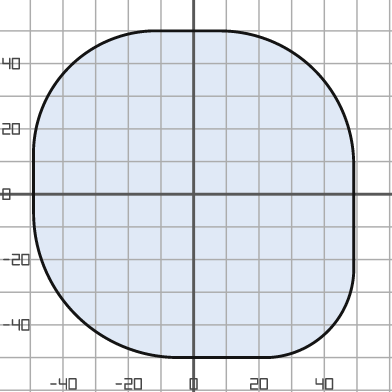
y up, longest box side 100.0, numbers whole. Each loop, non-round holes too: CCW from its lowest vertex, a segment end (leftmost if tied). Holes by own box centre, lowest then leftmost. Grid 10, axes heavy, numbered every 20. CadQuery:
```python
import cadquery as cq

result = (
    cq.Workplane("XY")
    .moveTo(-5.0, -50.0)
    .lineTo(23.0, -50.0)
    .threePointArc((41.0, -42.0), (49.0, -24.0))
    .lineTo(49.0, 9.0)
    .threePointArc((37.0, 38.0), (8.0, 50.0))
    .lineTo(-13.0, 50.0)
    .threePointArc((-38.0, 39.0), (-49.0, 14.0))
    .lineTo(-49.0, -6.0)
    .threePointArc((-36.0, -37.0), (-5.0, -50.0))
    .close()
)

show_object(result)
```